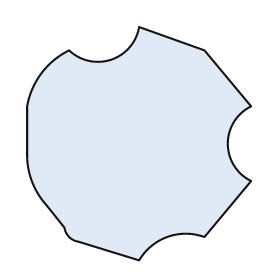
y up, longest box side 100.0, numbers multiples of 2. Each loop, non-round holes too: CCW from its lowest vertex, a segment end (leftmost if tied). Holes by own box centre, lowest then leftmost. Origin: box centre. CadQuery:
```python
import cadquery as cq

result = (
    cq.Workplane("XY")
    .moveTo(0.0, -50.0)
    .threePointArc((12.0, -40.0), (28.0, -40.0))
    .lineTo(48.0, -16.0)
    .threePointArc((38.0, 0.0), (48.0, 16.0))
    .lineTo(28.0, 40.0)
    .lineTo(0.0, 50.0)
    .threePointArc((-12.0, 36.0), (-30.0, 40.0))
    .threePointArc((-42.0, 30.0), (-48.0, 16.0))
    .lineTo(-48.0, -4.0)
    .threePointArc((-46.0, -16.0), (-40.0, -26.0))
    .lineTo(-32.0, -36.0)
    .threePointArc((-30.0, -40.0), (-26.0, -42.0))
    .close()
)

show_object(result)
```